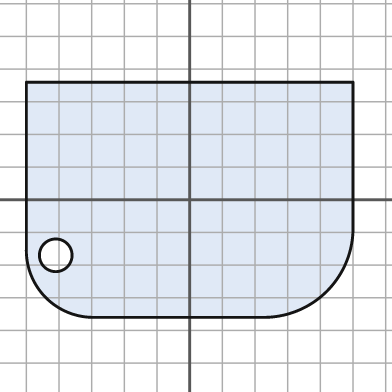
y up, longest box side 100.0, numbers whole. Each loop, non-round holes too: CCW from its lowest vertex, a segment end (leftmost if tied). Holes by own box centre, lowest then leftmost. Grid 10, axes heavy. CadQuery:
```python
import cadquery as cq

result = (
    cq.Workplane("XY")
    .moveTo(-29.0, -36.0)
    .lineTo(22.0, -36.0)
    .threePointArc((42.0, -28.0), (50.0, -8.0))
    .lineTo(50.0, 36.0)
    .lineTo(-50.0, 36.0)
    .lineTo(-50.0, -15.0)
    .threePointArc((-44.0, -30.0), (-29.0, -36.0))
    .close()
    .moveTo(-41.0, -17.0)
    .circle(5.0)
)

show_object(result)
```